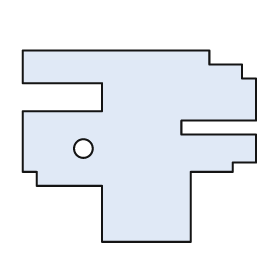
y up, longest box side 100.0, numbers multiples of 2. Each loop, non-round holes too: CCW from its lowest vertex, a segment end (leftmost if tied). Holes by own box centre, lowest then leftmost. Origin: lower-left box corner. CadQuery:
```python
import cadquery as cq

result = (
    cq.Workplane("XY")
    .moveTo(34.0, 0.0)
    .lineTo(72.0, 0.0)
    .lineTo(72.0, 30.0)
    .lineTo(90.0, 30.0)
    .lineTo(90.0, 34.0)
    .lineTo(100.0, 34.0)
    .lineTo(100.0, 46.0)
    .lineTo(68.0, 46.0)
    .lineTo(68.0, 52.0)
    .lineTo(100.0, 52.0)
    .lineTo(100.0, 70.0)
    .lineTo(94.0, 70.0)
    .lineTo(94.0, 76.0)
    .lineTo(80.0, 76.0)
    .lineTo(80.0, 82.0)
    .lineTo(0.0, 82.0)
    .lineTo(0.0, 68.0)
    .lineTo(34.0, 68.0)
    .lineTo(34.0, 56.0)
    .lineTo(0.0, 56.0)
    .lineTo(0.0, 30.0)
    .lineTo(6.0, 30.0)
    .lineTo(6.0, 24.0)
    .lineTo(34.0, 24.0)
    .close()
    .moveTo(26.0, 40.0)
    .circle(4.0)
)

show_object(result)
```